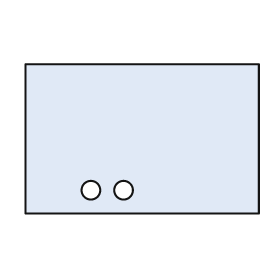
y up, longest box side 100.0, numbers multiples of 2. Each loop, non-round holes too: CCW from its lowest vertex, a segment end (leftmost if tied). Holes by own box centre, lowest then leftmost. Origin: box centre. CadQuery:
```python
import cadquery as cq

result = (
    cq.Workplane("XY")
    .moveTo(-50.0, -32.0)
    .lineTo(50.0, -32.0)
    .lineTo(50.0, 32.0)
    .lineTo(-50.0, 32.0)
    .close()
    .moveTo(-22.0, -22.0)
    .circle(4.0)
    .moveTo(-8.0, -22.0)
    .circle(4.0)
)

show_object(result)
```